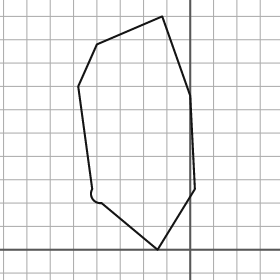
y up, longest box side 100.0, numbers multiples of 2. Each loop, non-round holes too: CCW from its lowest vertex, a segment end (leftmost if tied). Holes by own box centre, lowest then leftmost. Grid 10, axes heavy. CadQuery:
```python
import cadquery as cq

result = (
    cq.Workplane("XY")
    .moveTo(-14.0, 0.0)
    .lineTo(2.0, 26.0)
    .lineTo(0.0, 66.0)
    .lineTo(-12.0, 100.0)
    .lineTo(-40.0, 88.0)
    .lineTo(-48.0, 70.0)
    .lineTo(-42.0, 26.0)
    .threePointArc((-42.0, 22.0), (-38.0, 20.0))
    .close()
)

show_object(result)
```